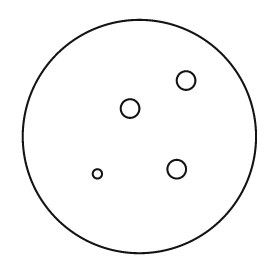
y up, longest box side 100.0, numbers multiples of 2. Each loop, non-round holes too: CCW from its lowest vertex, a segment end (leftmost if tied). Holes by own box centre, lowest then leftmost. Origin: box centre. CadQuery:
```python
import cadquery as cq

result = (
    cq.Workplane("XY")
    .moveTo(0.0, 0.0)
    .circle(50.0)
    .moveTo(-18.0, -16.0)
    .circle(2.0)
    .moveTo(16.0, -14.0)
    .circle(4.0)
    .moveTo(-4.0, 12.0)
    .circle(4.0)
    .moveTo(20.0, 24.0)
    .circle(4.0)
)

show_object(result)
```